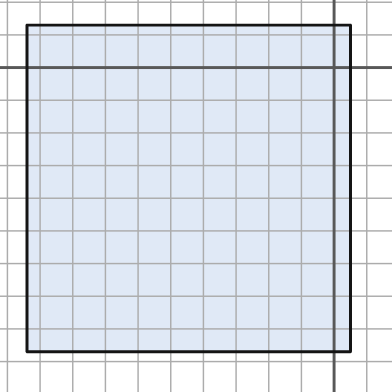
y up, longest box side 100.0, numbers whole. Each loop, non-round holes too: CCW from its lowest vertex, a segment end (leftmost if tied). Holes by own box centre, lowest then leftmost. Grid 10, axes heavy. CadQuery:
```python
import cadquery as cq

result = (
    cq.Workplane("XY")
    .moveTo(-94.0, -87.0)
    .lineTo(5.0, -87.0)
    .lineTo(5.0, 13.0)
    .lineTo(-94.0, 13.0)
    .close()
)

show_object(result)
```